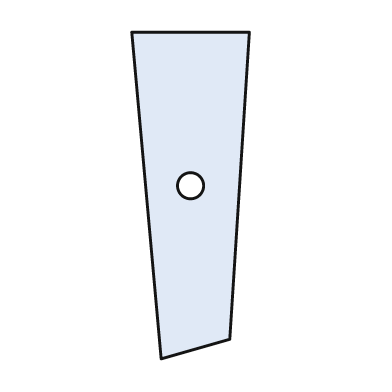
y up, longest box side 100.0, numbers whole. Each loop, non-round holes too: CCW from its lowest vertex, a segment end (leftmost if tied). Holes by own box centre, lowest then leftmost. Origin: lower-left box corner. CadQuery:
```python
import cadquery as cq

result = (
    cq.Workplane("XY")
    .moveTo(9.0, 0.0)
    .lineTo(30.0, 6.0)
    .lineTo(36.0, 100.0)
    .lineTo(0.0, 100.0)
    .close()
    .moveTo(18.0, 53.0)
    .circle(4.0)
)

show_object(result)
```